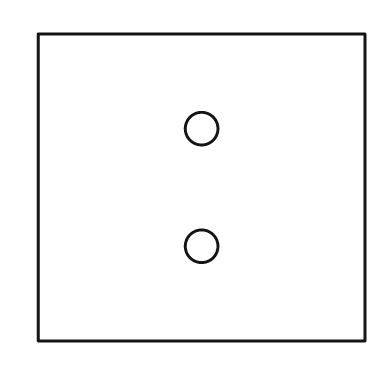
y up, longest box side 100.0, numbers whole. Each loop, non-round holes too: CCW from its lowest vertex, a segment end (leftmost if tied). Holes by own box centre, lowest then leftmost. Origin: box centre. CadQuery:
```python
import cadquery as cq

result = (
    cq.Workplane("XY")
    .moveTo(-50.0, -47.0)
    .lineTo(50.0, -47.0)
    .lineTo(50.0, 47.0)
    .lineTo(-50.0, 47.0)
    .close()
    .moveTo(0.0, -18.0)
    .circle(5.0)
    .moveTo(0.0, 18.0)
    .circle(5.0)
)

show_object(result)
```